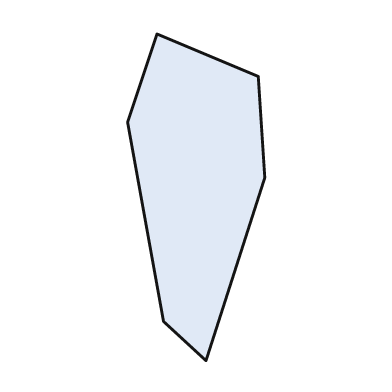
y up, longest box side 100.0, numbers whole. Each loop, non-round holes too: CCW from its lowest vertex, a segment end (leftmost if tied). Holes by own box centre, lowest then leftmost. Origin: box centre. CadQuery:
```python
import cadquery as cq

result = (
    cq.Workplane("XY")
    .moveTo(3.0, -50.0)
    .lineTo(21.0, 6.0)
    .lineTo(19.0, 37.0)
    .lineTo(-12.0, 50.0)
    .lineTo(-21.0, 23.0)
    .lineTo(-10.0, -38.0)
    .close()
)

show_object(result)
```